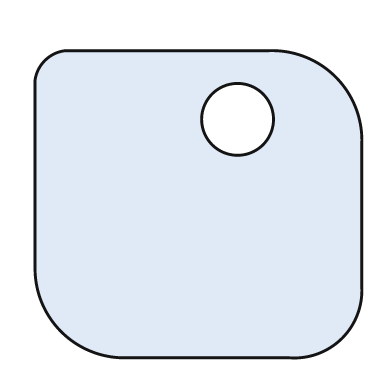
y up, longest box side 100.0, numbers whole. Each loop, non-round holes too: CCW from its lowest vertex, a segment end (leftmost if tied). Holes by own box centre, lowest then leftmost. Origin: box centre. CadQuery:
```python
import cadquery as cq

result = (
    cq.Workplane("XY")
    .moveTo(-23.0, -47.0)
    .lineTo(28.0, -47.0)
    .threePointArc((44.0, -41.0), (50.0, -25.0))
    .lineTo(50.0, 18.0)
    .threePointArc((42.0, 39.0), (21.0, 47.0))
    .lineTo(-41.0, 47.0)
    .threePointArc((-47.0, 44.0), (-50.0, 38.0))
    .lineTo(-50.0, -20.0)
    .threePointArc((-42.0, -39.0), (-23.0, -47.0))
    .close()
    .moveTo(12.0, 26.0)
    .circle(11.0)
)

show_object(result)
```